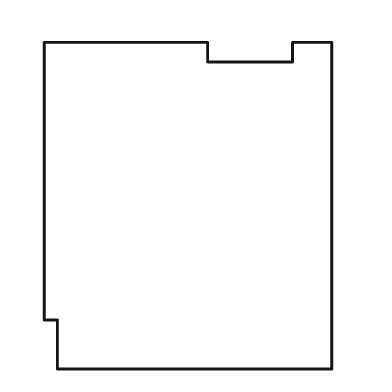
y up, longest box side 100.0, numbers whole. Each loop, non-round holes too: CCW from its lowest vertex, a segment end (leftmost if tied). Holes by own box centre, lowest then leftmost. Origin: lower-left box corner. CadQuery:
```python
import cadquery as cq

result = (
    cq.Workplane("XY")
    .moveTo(4.0, 0.0)
    .lineTo(88.0, 0.0)
    .lineTo(88.0, 100.0)
    .lineTo(76.0, 100.0)
    .lineTo(76.0, 94.0)
    .lineTo(50.0, 94.0)
    .lineTo(50.0, 100.0)
    .lineTo(0.0, 100.0)
    .lineTo(0.0, 15.0)
    .lineTo(4.0, 15.0)
    .close()
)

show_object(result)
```